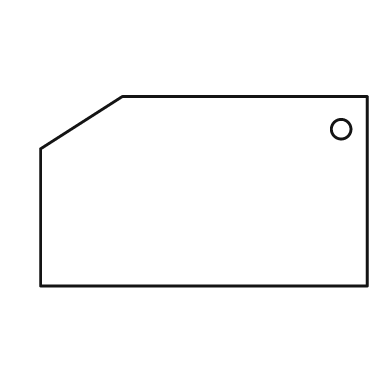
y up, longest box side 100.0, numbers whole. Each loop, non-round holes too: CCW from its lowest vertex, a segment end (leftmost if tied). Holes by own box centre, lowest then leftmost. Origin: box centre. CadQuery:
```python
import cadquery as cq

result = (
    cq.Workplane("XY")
    .moveTo(-50.0, -29.0)
    .lineTo(50.0, -29.0)
    .lineTo(50.0, 29.0)
    .lineTo(-25.0, 29.0)
    .lineTo(-50.0, 13.0)
    .close()
    .moveTo(42.0, 19.0)
    .circle(3.0)
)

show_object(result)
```